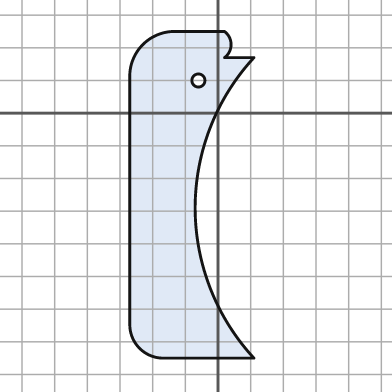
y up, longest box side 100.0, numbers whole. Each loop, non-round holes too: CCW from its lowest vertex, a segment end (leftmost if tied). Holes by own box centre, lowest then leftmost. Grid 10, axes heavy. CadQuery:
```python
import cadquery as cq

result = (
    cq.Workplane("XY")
    .moveTo(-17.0, -75.0)
    .lineTo(11.0, -75.0)
    .threePointArc((-7.0, -29.0), (11.0, 17.0))
    .lineTo(2.0, 17.0)
    .threePointArc((4.0, 21.0), (2.0, 25.0))
    .lineTo(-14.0, 25.0)
    .threePointArc((-23.0, 21.0), (-27.0, 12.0))
    .lineTo(-27.0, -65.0)
    .threePointArc((-24.0, -72.0), (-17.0, -75.0))
    .close()
    .moveTo(-6.0, 10.0)
    .circle(2.0)
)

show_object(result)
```